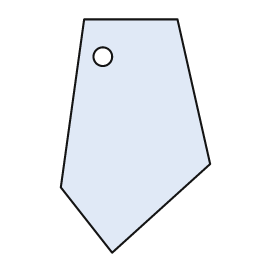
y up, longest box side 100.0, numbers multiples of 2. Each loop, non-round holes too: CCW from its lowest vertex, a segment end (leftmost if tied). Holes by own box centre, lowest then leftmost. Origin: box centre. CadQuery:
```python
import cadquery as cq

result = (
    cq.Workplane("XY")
    .moveTo(-10.0, -50.0)
    .lineTo(32.0, -12.0)
    .lineTo(18.0, 50.0)
    .lineTo(-22.0, 50.0)
    .lineTo(-32.0, -22.0)
    .close()
    .moveTo(-14.0, 34.0)
    .circle(4.0)
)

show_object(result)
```